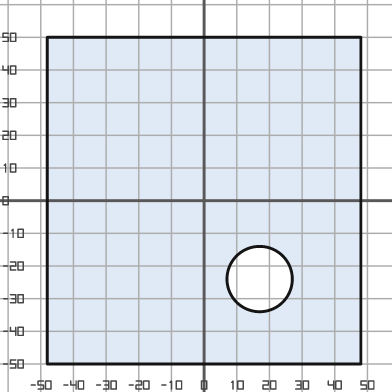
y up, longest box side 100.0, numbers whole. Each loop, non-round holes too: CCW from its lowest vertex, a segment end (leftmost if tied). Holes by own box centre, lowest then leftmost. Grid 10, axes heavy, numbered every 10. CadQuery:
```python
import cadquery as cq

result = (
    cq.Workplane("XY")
    .moveTo(-48.0, -50.0)
    .lineTo(48.0, -50.0)
    .lineTo(48.0, 50.0)
    .lineTo(-48.0, 50.0)
    .close()
    .moveTo(17.0, -24.0)
    .circle(10.0)
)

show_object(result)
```